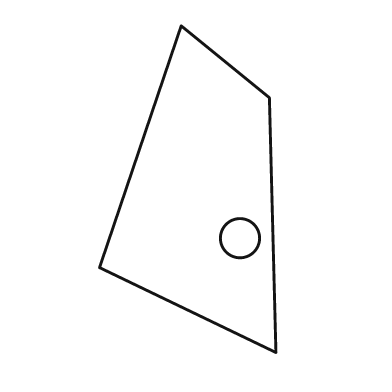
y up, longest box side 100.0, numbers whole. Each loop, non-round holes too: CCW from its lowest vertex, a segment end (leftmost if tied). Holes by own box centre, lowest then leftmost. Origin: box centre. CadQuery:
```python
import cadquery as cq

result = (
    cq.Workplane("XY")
    .moveTo(27.0, -50.0)
    .lineTo(25.0, 28.0)
    .lineTo(-2.0, 50.0)
    .lineTo(-27.0, -24.0)
    .close()
    .moveTo(16.0, -15.0)
    .circle(6.0)
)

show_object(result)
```